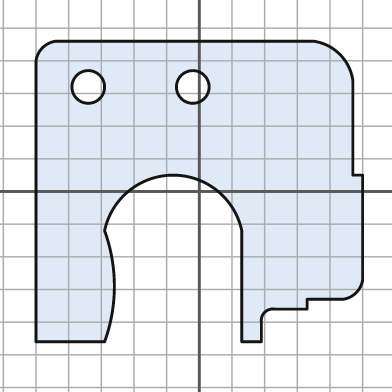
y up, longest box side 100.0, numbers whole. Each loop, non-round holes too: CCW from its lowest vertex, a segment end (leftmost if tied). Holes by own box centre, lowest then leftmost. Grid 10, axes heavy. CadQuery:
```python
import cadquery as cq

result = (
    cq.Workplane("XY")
    .moveTo(-50.0, -46.0)
    .lineTo(-29.0, -46.0)
    .threePointArc((-26.0, -29.0), (-29.0, -12.0))
    .threePointArc((-8.0, 5.0), (13.0, -12.0))
    .lineTo(13.0, -46.0)
    .lineTo(19.0, -46.0)
    .lineTo(19.0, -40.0)
    .threePointArc((20.0, -37.0), (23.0, -36.0))
    .lineTo(33.0, -36.0)
    .lineTo(33.0, -33.0)
    .lineTo(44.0, -33.0)
    .threePointArc((48.0, -31.0), (50.0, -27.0))
    .lineTo(50.0, 5.0)
    .lineTo(47.0, 5.0)
    .lineTo(47.0, 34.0)
    .threePointArc((43.0, 42.0), (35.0, 46.0))
    .lineTo(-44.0, 46.0)
    .threePointArc((-48.0, 44.0), (-50.0, 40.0))
    .close()
    .moveTo(-34.0, 32.0)
    .circle(5.0)
    .moveTo(-2.0, 32.0)
    .circle(5.0)
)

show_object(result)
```